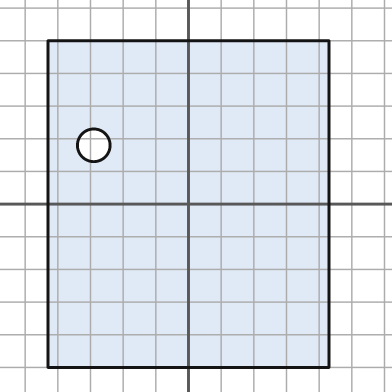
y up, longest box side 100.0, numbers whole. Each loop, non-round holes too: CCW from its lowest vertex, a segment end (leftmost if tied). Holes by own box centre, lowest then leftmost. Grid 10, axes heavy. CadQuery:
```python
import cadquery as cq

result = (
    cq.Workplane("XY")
    .moveTo(-43.0, -50.0)
    .lineTo(43.0, -50.0)
    .lineTo(43.0, 50.0)
    .lineTo(-43.0, 50.0)
    .close()
    .moveTo(-29.0, 18.0)
    .circle(5.0)
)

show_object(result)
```